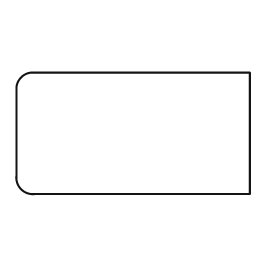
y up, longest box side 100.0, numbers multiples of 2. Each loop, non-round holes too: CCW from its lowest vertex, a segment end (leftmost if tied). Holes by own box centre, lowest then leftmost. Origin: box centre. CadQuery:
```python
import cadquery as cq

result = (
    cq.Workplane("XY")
    .moveTo(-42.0, -26.0)
    .lineTo(50.0, -26.0)
    .lineTo(50.0, 26.0)
    .lineTo(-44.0, 26.0)
    .threePointArc((-48.0, 24.0), (-50.0, 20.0))
    .lineTo(-50.0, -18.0)
    .threePointArc((-48.0, -24.0), (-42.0, -26.0))
    .close()
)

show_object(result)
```